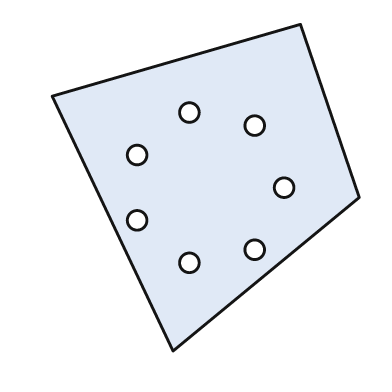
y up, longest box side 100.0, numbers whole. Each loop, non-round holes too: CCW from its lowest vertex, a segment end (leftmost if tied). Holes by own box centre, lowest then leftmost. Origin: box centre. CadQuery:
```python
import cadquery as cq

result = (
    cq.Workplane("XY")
    .moveTo(-10.0, -50.0)
    .lineTo(47.0, -3.0)
    .lineTo(29.0, 50.0)
    .lineTo(-47.0, 28.0)
    .close()
    .moveTo(-5.0, -23.0)
    .circle(3.0)
    .moveTo(15.0, -19.0)
    .circle(3.0)
    .moveTo(-21.0, -10.0)
    .circle(3.0)
    .moveTo(24.0, 0.0)
    .circle(3.0)
    .moveTo(-21.0, 10.0)
    .circle(3.0)
    .moveTo(15.0, 19.0)
    .circle(3.0)
    .moveTo(-5.0, 23.0)
    .circle(3.0)
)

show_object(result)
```